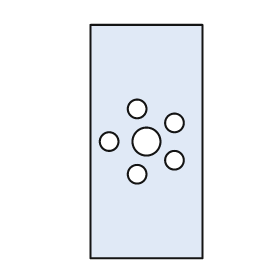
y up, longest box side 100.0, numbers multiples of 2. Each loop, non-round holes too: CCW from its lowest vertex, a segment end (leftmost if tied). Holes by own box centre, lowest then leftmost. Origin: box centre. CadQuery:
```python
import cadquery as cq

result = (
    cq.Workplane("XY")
    .moveTo(-24.0, -50.0)
    .lineTo(24.0, -50.0)
    .lineTo(24.0, 50.0)
    .lineTo(-24.0, 50.0)
    .close()
    .moveTo(-4.0, -14.0)
    .circle(4.0)
    .moveTo(12.0, -8.0)
    .circle(4.0)
    .moveTo(-16.0, 0.0)
    .circle(4.0)
    .moveTo(0.0, 0.0)
    .circle(6.0)
    .moveTo(12.0, 8.0)
    .circle(4.0)
    .moveTo(-4.0, 14.0)
    .circle(4.0)
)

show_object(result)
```